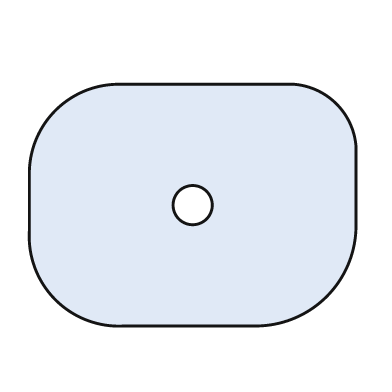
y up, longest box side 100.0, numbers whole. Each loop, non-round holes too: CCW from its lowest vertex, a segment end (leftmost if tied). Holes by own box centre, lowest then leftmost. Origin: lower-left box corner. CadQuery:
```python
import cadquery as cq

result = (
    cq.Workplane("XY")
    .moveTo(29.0, 0.0)
    .lineTo(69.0, 0.0)
    .threePointArc((91.0, 9.0), (100.0, 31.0))
    .lineTo(100.0, 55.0)
    .threePointArc((94.0, 68.0), (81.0, 74.0))
    .lineTo(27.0, 74.0)
    .threePointArc((8.0, 66.0), (0.0, 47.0))
    .lineTo(0.0, 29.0)
    .threePointArc((8.0, 8.0), (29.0, 0.0))
    .close()
    .moveTo(50.0, 37.0)
    .circle(6.0)
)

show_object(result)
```